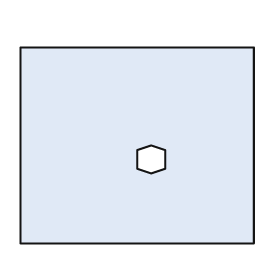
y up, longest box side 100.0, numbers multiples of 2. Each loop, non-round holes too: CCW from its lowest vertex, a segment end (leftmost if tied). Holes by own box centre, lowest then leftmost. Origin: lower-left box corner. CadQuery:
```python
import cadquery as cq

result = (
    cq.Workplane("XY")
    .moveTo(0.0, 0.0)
    .lineTo(100.0, 0.0)
    .lineTo(100.0, 84.0)
    .lineTo(0.0, 84.0)
    .close()
    .moveTo(56.0, 30.0)
    .lineTo(62.0, 32.0)
    .lineTo(62.0, 40.0)
    .lineTo(56.0, 42.0)
    .lineTo(50.0, 40.0)
    .lineTo(50.0, 32.0)
    .close()
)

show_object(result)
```